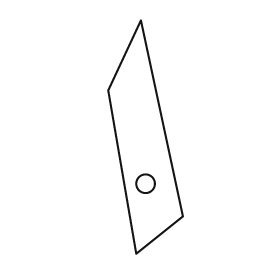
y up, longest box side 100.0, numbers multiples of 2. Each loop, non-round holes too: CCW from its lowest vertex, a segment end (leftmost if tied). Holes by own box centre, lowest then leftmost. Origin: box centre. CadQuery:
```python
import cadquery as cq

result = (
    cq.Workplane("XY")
    .moveTo(-4.0, -50.0)
    .lineTo(16.0, -34.0)
    .lineTo(-2.0, 50.0)
    .lineTo(-16.0, 20.0)
    .close()
    .moveTo(0.0, -20.0)
    .circle(4.0)
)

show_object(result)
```